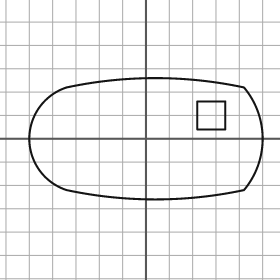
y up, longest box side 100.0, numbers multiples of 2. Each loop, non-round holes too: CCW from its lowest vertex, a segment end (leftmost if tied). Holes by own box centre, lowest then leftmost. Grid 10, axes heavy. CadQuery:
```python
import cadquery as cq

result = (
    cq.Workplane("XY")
    .moveTo(-34.0, -22.0)
    .threePointArc((4.0, -26.0), (42.0, -22.0))
    .threePointArc((50.0, 0.0), (42.0, 22.0))
    .threePointArc((4.0, 26.0), (-34.0, 22.0))
    .threePointArc((-50.0, 0.0), (-34.0, -22.0))
    .close()
    .moveTo(22.0, 4.0)
    .lineTo(34.0, 4.0)
    .lineTo(34.0, 16.0)
    .lineTo(22.0, 16.0)
    .close()
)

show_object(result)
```